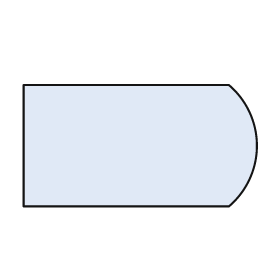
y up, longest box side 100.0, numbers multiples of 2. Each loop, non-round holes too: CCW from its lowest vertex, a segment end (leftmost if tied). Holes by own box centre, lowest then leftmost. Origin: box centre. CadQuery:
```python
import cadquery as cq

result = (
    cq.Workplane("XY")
    .moveTo(-50.0, -26.0)
    .lineTo(38.0, -26.0)
    .threePointArc((50.0, 0.0), (38.0, 26.0))
    .lineTo(-50.0, 26.0)
    .close()
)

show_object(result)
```